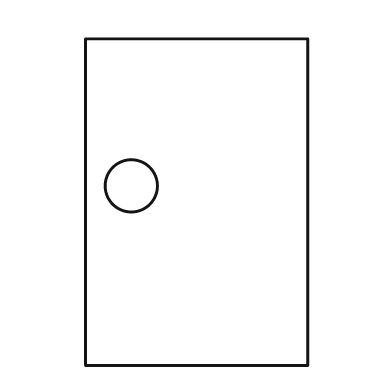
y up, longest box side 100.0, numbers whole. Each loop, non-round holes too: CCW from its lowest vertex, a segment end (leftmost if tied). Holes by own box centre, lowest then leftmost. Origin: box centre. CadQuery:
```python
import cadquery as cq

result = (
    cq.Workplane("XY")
    .moveTo(-34.0, -50.0)
    .lineTo(34.0, -50.0)
    .lineTo(34.0, 50.0)
    .lineTo(-34.0, 50.0)
    .close()
    .moveTo(-20.0, 5.0)
    .circle(8.0)
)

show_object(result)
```